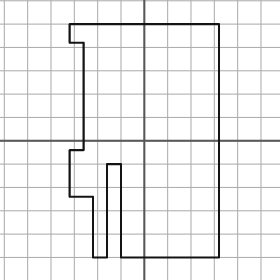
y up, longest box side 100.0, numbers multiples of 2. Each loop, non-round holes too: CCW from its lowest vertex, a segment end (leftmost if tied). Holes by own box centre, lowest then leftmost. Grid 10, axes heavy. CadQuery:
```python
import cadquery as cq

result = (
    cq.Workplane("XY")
    .moveTo(-22.0, -50.0)
    .lineTo(-16.0, -50.0)
    .lineTo(-16.0, -10.0)
    .lineTo(-10.0, -10.0)
    .lineTo(-10.0, -50.0)
    .lineTo(32.0, -50.0)
    .lineTo(32.0, 50.0)
    .lineTo(-32.0, 50.0)
    .lineTo(-32.0, 42.0)
    .lineTo(-26.0, 42.0)
    .lineTo(-26.0, -4.0)
    .lineTo(-32.0, -4.0)
    .lineTo(-32.0, -24.0)
    .lineTo(-22.0, -24.0)
    .close()
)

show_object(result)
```